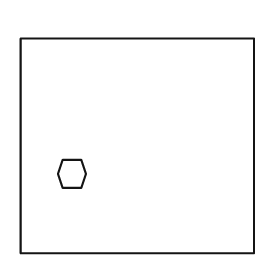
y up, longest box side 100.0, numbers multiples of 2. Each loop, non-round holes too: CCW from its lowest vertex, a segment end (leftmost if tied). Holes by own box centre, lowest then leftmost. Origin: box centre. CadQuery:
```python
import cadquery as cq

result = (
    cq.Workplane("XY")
    .moveTo(-50.0, -46.0)
    .lineTo(50.0, -46.0)
    .lineTo(50.0, 46.0)
    .lineTo(-50.0, 46.0)
    .close()
    .moveTo(-32.0, -18.0)
    .lineTo(-24.0, -18.0)
    .lineTo(-22.0, -12.0)
    .lineTo(-24.0, -6.0)
    .lineTo(-32.0, -6.0)
    .lineTo(-34.0, -12.0)
    .close()
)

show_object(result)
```